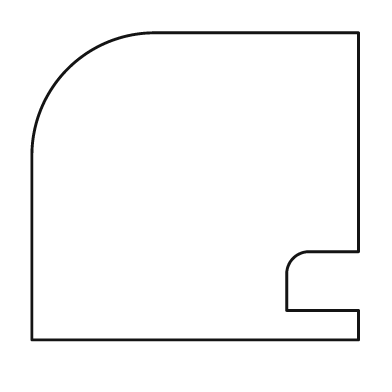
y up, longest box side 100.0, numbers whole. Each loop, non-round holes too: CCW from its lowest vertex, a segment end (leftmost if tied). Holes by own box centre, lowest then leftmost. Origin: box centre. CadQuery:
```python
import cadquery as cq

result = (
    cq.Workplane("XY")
    .moveTo(-50.0, -47.0)
    .lineTo(50.0, -47.0)
    .lineTo(50.0, -38.0)
    .lineTo(28.0, -38.0)
    .lineTo(28.0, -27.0)
    .threePointArc((30.0, -22.0), (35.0, -20.0))
    .lineTo(50.0, -20.0)
    .lineTo(50.0, 47.0)
    .lineTo(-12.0, 47.0)
    .threePointArc((-39.0, 36.0), (-50.0, 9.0))
    .close()
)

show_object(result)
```